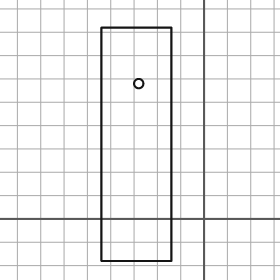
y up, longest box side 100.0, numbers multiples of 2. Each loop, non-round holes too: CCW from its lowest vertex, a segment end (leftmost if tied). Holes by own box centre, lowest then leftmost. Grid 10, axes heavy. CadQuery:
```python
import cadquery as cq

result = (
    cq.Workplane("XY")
    .moveTo(-44.0, -18.0)
    .lineTo(-14.0, -18.0)
    .lineTo(-14.0, 82.0)
    .lineTo(-44.0, 82.0)
    .close()
    .moveTo(-28.0, 58.0)
    .circle(2.0)
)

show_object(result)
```